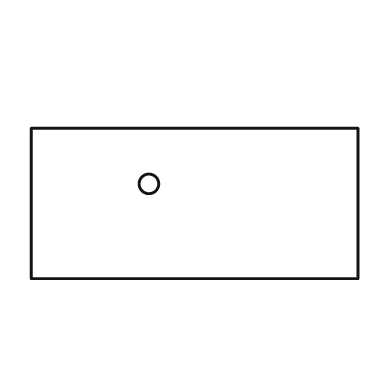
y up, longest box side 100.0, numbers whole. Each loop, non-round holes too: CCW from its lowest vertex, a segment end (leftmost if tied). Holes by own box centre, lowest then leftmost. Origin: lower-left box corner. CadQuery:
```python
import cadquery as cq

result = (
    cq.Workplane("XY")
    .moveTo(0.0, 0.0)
    .lineTo(100.0, 0.0)
    .lineTo(100.0, 46.0)
    .lineTo(0.0, 46.0)
    .close()
    .moveTo(36.0, 29.0)
    .circle(3.0)
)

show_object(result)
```